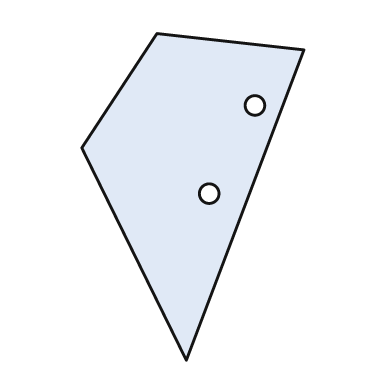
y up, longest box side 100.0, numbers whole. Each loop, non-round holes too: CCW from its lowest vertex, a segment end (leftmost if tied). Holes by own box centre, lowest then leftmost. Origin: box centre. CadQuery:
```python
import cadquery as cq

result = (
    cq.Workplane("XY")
    .moveTo(-2.0, -50.0)
    .lineTo(34.0, 45.0)
    .lineTo(-11.0, 50.0)
    .lineTo(-34.0, 15.0)
    .close()
    .moveTo(5.0, 1.0)
    .circle(3.0)
    .moveTo(19.0, 28.0)
    .circle(3.0)
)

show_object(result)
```